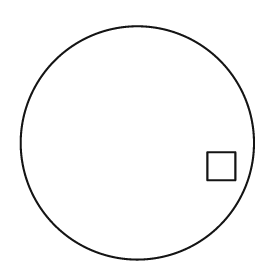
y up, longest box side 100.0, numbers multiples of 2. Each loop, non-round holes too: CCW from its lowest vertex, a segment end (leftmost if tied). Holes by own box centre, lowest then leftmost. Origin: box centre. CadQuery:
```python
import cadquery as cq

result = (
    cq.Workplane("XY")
    .moveTo(0.0, 0.0)
    .circle(50.0)
    .moveTo(30.0, -16.0)
    .lineTo(42.0, -16.0)
    .lineTo(42.0, -4.0)
    .lineTo(30.0, -4.0)
    .close()
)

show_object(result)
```